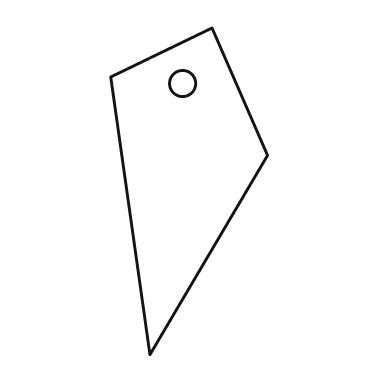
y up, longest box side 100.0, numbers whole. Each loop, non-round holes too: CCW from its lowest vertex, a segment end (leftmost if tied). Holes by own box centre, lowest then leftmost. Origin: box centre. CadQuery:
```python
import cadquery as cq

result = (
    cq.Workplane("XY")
    .moveTo(-12.0, -50.0)
    .lineTo(24.0, 11.0)
    .lineTo(7.0, 50.0)
    .lineTo(-24.0, 35.0)
    .close()
    .moveTo(-2.0, 33.0)
    .circle(4.0)
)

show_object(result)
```